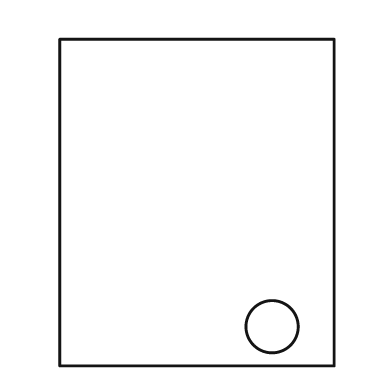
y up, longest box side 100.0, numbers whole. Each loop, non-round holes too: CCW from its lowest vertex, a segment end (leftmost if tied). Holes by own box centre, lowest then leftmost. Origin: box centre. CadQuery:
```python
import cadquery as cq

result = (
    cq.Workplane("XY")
    .moveTo(-42.0, -50.0)
    .lineTo(42.0, -50.0)
    .lineTo(42.0, 50.0)
    .lineTo(-42.0, 50.0)
    .close()
    .moveTo(23.0, -38.0)
    .circle(8.0)
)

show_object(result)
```